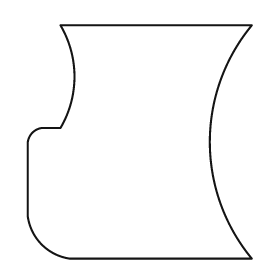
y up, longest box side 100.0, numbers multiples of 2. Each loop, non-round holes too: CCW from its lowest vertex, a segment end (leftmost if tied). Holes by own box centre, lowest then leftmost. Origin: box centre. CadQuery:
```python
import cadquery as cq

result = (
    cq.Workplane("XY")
    .moveTo(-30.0, -50.0)
    .lineTo(48.0, -50.0)
    .threePointArc((30.0, 0.0), (48.0, 50.0))
    .lineTo(-34.0, 50.0)
    .threePointArc((-28.0, 28.0), (-34.0, 6.0))
    .lineTo(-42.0, 6.0)
    .threePointArc((-46.0, 4.0), (-48.0, 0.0))
    .lineTo(-48.0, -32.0)
    .threePointArc((-42.0, -44.0), (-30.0, -50.0))
    .close()
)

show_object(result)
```